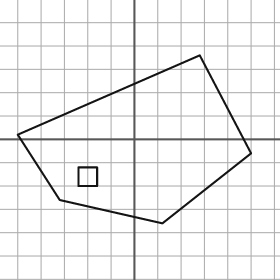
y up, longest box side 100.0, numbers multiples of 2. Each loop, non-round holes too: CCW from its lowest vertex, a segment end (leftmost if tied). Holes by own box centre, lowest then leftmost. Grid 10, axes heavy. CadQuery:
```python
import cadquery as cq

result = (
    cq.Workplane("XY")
    .moveTo(12.0, -36.0)
    .lineTo(50.0, -6.0)
    .lineTo(28.0, 36.0)
    .lineTo(-50.0, 2.0)
    .lineTo(-32.0, -26.0)
    .close()
    .moveTo(-24.0, -20.0)
    .lineTo(-16.0, -20.0)
    .lineTo(-16.0, -12.0)
    .lineTo(-24.0, -12.0)
    .close()
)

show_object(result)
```